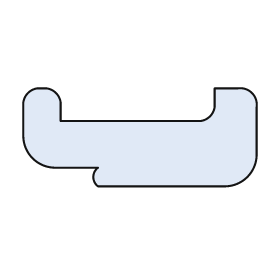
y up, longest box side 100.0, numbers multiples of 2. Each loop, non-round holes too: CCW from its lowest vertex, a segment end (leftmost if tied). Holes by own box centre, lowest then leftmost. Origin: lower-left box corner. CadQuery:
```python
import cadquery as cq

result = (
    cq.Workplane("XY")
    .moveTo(32.0, 0.0)
    .lineTo(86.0, 0.0)
    .threePointArc((96.0, 4.0), (100.0, 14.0))
    .lineTo(100.0, 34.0)
    .threePointArc((98.0, 40.0), (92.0, 42.0))
    .lineTo(82.0, 42.0)
    .lineTo(82.0, 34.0)
    .threePointArc((80.0, 30.0), (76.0, 28.0))
    .lineTo(16.0, 28.0)
    .lineTo(16.0, 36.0)
    .threePointArc((14.0, 40.0), (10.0, 42.0))
    .lineTo(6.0, 42.0)
    .threePointArc((2.0, 40.0), (0.0, 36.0))
    .lineTo(0.0, 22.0)
    .threePointArc((4.0, 12.0), (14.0, 8.0))
    .lineTo(32.0, 8.0)
    .threePointArc((30.0, 4.0), (32.0, 0.0))
    .close()
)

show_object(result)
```